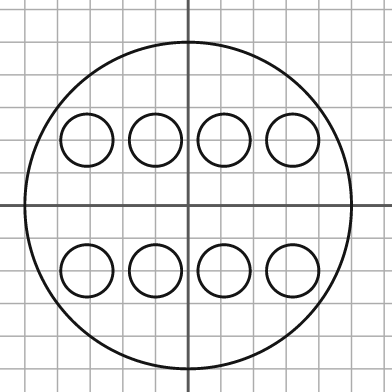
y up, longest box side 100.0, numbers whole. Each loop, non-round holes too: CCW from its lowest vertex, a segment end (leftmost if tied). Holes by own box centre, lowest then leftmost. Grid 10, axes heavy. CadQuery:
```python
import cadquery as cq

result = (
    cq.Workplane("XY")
    .moveTo(0.0, 0.0)
    .circle(50.0)
    .moveTo(-31.0, -20.0)
    .circle(8.0)
    .moveTo(-10.0, -20.0)
    .circle(8.0)
    .moveTo(11.0, -20.0)
    .circle(8.0)
    .moveTo(32.0, -20.0)
    .circle(8.0)
    .moveTo(-31.0, 20.0)
    .circle(8.0)
    .moveTo(-10.0, 20.0)
    .circle(8.0)
    .moveTo(11.0, 20.0)
    .circle(8.0)
    .moveTo(32.0, 20.0)
    .circle(8.0)
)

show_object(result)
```